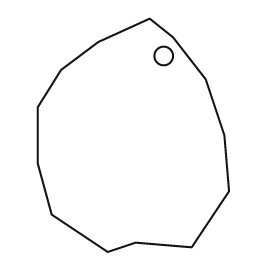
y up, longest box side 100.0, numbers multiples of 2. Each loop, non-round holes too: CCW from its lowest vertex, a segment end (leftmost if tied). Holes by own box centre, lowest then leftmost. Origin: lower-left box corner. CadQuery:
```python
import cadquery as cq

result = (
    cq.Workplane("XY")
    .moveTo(30.0, 0.0)
    .lineTo(42.0, 4.0)
    .lineTo(66.0, 2.0)
    .lineTo(82.0, 26.0)
    .lineTo(80.0, 50.0)
    .lineTo(72.0, 74.0)
    .lineTo(58.0, 92.0)
    .lineTo(48.0, 100.0)
    .lineTo(26.0, 90.0)
    .lineTo(10.0, 78.0)
    .lineTo(0.0, 62.0)
    .lineTo(0.0, 38.0)
    .lineTo(6.0, 16.0)
    .close()
    .moveTo(54.0, 84.0)
    .circle(4.0)
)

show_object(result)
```